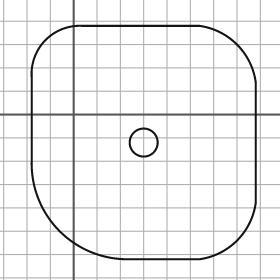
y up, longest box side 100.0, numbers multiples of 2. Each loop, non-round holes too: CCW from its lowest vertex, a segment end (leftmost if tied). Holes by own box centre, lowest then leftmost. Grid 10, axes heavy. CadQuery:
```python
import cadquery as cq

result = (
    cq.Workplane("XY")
    .moveTo(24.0, -62.0)
    .lineTo(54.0, -62.0)
    .threePointArc((70.0, -54.0), (78.0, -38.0))
    .lineTo(78.0, 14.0)
    .threePointArc((70.0, 30.0), (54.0, 38.0))
    .lineTo(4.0, 38.0)
    .threePointArc((-12.0, 32.0), (-18.0, 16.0))
    .lineTo(-18.0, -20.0)
    .threePointArc((-6.0, -50.0), (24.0, -62.0))
    .close()
    .moveTo(30.0, -12.0)
    .circle(6.0)
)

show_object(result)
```